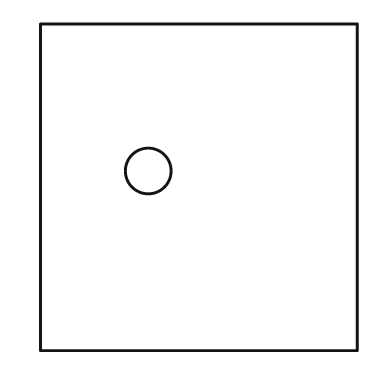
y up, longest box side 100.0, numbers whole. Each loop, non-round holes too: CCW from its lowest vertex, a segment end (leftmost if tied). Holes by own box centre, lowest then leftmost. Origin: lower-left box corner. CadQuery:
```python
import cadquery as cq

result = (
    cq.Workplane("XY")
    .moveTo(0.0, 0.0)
    .lineTo(97.0, 0.0)
    .lineTo(97.0, 100.0)
    .lineTo(0.0, 100.0)
    .close()
    .moveTo(33.0, 55.0)
    .circle(7.0)
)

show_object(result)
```